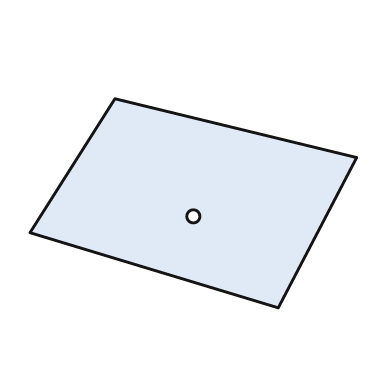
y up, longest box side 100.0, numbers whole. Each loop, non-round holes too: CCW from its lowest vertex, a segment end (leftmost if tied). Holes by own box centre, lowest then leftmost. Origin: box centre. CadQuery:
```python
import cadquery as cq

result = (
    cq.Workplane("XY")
    .moveTo(26.0, -32.0)
    .lineTo(50.0, 14.0)
    .lineTo(-24.0, 32.0)
    .lineTo(-50.0, -9.0)
    .close()
    .moveTo(0.0, -4.0)
    .circle(2.0)
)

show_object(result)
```